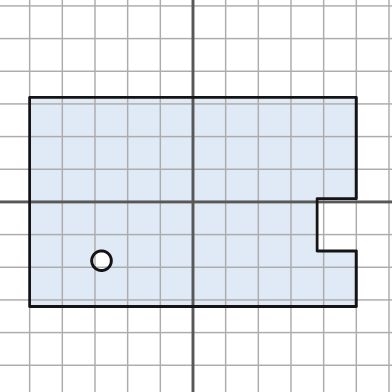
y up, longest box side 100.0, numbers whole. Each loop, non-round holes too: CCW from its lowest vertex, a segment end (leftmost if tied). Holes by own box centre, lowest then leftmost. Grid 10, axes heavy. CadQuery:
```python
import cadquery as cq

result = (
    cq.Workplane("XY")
    .moveTo(-50.0, -32.0)
    .lineTo(50.0, -32.0)
    .lineTo(50.0, -15.0)
    .lineTo(38.0, -15.0)
    .lineTo(38.0, 1.0)
    .lineTo(50.0, 1.0)
    .lineTo(50.0, 32.0)
    .lineTo(-50.0, 32.0)
    .close()
    .moveTo(-28.0, -18.0)
    .circle(3.0)
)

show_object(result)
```